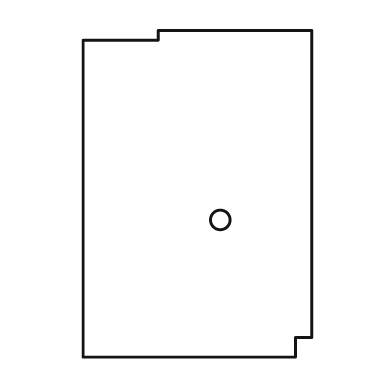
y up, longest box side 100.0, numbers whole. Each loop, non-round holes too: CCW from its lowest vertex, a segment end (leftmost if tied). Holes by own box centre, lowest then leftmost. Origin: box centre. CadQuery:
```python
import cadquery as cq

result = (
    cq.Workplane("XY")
    .moveTo(-35.0, -50.0)
    .lineTo(30.0, -50.0)
    .lineTo(30.0, -44.0)
    .lineTo(35.0, -44.0)
    .lineTo(35.0, 50.0)
    .lineTo(-12.0, 50.0)
    .lineTo(-12.0, 47.0)
    .lineTo(-35.0, 47.0)
    .close()
    .moveTo(7.0, -8.0)
    .circle(3.0)
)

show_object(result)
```